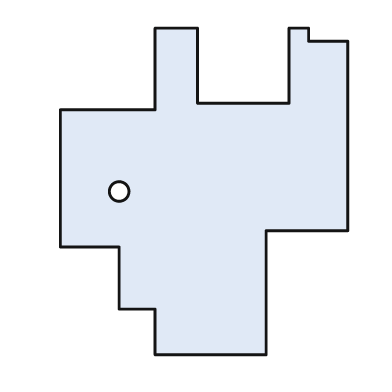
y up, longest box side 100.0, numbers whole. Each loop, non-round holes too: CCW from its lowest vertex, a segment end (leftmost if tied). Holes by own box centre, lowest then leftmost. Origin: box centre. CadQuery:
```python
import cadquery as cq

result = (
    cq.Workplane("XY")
    .moveTo(-15.0, -50.0)
    .lineTo(19.0, -50.0)
    .lineTo(19.0, -12.0)
    .lineTo(44.0, -12.0)
    .lineTo(44.0, 46.0)
    .lineTo(32.0, 46.0)
    .lineTo(32.0, 50.0)
    .lineTo(26.0, 50.0)
    .lineTo(26.0, 27.0)
    .lineTo(-2.0, 27.0)
    .lineTo(-2.0, 50.0)
    .lineTo(-15.0, 50.0)
    .lineTo(-15.0, 25.0)
    .lineTo(-44.0, 25.0)
    .lineTo(-44.0, -17.0)
    .lineTo(-26.0, -17.0)
    .lineTo(-26.0, -36.0)
    .lineTo(-15.0, -36.0)
    .close()
    .moveTo(-26.0, 0.0)
    .circle(3.0)
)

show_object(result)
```